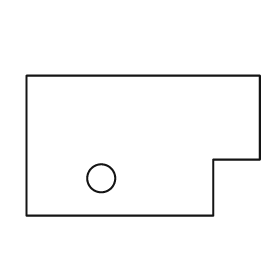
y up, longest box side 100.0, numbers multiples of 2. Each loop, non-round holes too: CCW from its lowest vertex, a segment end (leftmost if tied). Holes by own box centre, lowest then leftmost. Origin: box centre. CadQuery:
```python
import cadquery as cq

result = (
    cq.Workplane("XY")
    .moveTo(-50.0, -30.0)
    .lineTo(30.0, -30.0)
    .lineTo(30.0, -6.0)
    .lineTo(50.0, -6.0)
    .lineTo(50.0, 30.0)
    .lineTo(-50.0, 30.0)
    .close()
    .moveTo(-18.0, -14.0)
    .circle(6.0)
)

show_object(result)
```